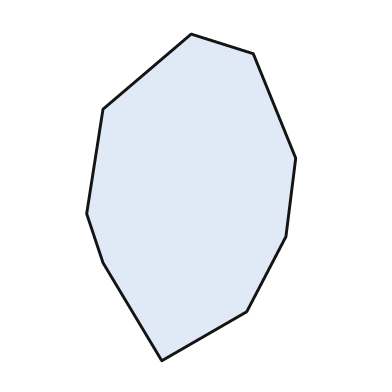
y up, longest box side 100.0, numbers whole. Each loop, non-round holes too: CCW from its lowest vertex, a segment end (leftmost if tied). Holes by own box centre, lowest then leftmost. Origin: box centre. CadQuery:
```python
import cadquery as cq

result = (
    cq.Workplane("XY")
    .moveTo(-9.0, -50.0)
    .lineTo(17.0, -35.0)
    .lineTo(29.0, -12.0)
    .lineTo(32.0, 12.0)
    .lineTo(19.0, 44.0)
    .lineTo(0.0, 50.0)
    .lineTo(-27.0, 27.0)
    .lineTo(-32.0, -5.0)
    .lineTo(-27.0, -20.0)
    .close()
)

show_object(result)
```